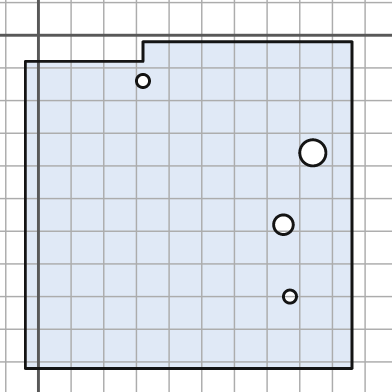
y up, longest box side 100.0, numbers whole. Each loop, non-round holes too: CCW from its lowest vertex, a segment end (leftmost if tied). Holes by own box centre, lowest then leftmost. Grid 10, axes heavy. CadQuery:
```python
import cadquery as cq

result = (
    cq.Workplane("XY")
    .moveTo(-4.0, -102.0)
    .lineTo(96.0, -102.0)
    .lineTo(96.0, -2.0)
    .lineTo(32.0, -2.0)
    .lineTo(32.0, -8.0)
    .lineTo(-4.0, -8.0)
    .close()
    .moveTo(77.0, -80.0)
    .circle(2.0)
    .moveTo(75.0, -58.0)
    .circle(3.0)
    .moveTo(84.0, -36.0)
    .circle(4.0)
    .moveTo(32.0, -14.0)
    .circle(2.0)
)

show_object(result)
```